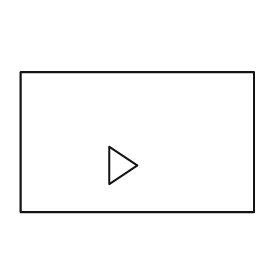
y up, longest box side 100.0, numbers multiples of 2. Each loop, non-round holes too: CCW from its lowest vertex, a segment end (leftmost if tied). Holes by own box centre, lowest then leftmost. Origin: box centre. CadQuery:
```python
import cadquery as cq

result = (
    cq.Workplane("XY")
    .moveTo(-50.0, -30.0)
    .lineTo(50.0, -30.0)
    .lineTo(50.0, 30.0)
    .lineTo(-50.0, 30.0)
    .close()
    .moveTo(-12.0, -18.0)
    .lineTo(0.0, -10.0)
    .lineTo(-12.0, -2.0)
    .close()
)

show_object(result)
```